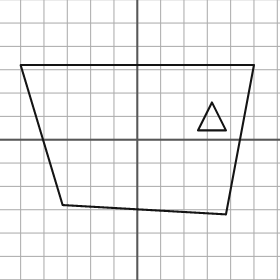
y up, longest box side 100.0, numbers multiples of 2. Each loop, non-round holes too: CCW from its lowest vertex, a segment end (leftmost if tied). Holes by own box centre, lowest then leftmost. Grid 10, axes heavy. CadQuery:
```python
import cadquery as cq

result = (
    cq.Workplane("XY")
    .moveTo(38.0, -32.0)
    .lineTo(50.0, 32.0)
    .lineTo(-50.0, 32.0)
    .lineTo(-32.0, -28.0)
    .close()
    .moveTo(26.0, 4.0)
    .lineTo(38.0, 4.0)
    .lineTo(32.0, 16.0)
    .close()
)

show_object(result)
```